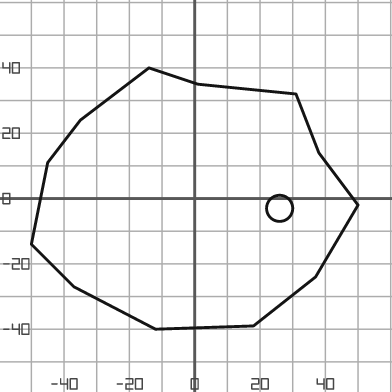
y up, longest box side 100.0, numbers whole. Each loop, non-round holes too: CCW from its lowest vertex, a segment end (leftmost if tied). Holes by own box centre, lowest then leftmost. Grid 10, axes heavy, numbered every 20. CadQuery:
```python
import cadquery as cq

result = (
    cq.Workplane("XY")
    .moveTo(-12.0, -40.0)
    .lineTo(18.0, -39.0)
    .lineTo(37.0, -24.0)
    .lineTo(50.0, -2.0)
    .lineTo(38.0, 14.0)
    .lineTo(31.0, 32.0)
    .lineTo(1.0, 35.0)
    .lineTo(-14.0, 40.0)
    .lineTo(-35.0, 24.0)
    .lineTo(-45.0, 11.0)
    .lineTo(-50.0, -14.0)
    .lineTo(-37.0, -27.0)
    .close()
    .moveTo(26.0, -3.0)
    .circle(4.0)
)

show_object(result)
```